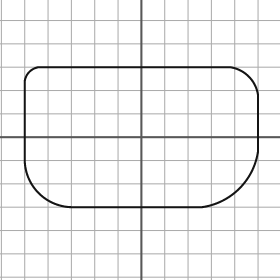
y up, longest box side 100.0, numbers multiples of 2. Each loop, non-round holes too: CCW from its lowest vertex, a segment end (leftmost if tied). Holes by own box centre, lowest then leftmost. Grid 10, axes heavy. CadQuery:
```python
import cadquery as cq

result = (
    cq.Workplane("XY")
    .moveTo(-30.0, -30.0)
    .lineTo(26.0, -30.0)
    .threePointArc((42.0, -22.0), (50.0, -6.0))
    .lineTo(50.0, 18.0)
    .threePointArc((46.0, 26.0), (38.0, 30.0))
    .lineTo(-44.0, 30.0)
    .threePointArc((-48.0, 28.0), (-50.0, 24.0))
    .lineTo(-50.0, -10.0)
    .threePointArc((-44.0, -24.0), (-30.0, -30.0))
    .close()
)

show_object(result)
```